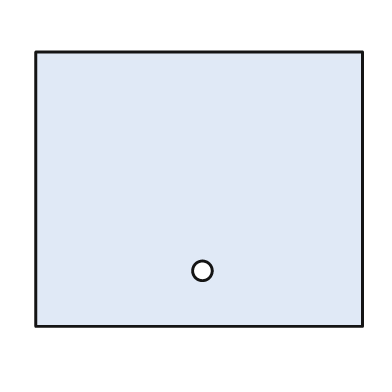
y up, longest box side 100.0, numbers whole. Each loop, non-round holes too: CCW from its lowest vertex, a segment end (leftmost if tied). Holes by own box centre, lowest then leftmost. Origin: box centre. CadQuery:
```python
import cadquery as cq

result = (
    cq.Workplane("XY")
    .moveTo(-50.0, -42.0)
    .lineTo(50.0, -42.0)
    .lineTo(50.0, 42.0)
    .lineTo(-50.0, 42.0)
    .close()
    .moveTo(1.0, -25.0)
    .circle(3.0)
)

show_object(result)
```